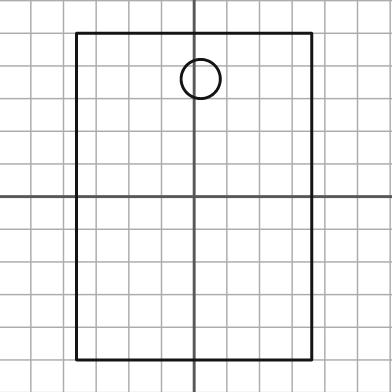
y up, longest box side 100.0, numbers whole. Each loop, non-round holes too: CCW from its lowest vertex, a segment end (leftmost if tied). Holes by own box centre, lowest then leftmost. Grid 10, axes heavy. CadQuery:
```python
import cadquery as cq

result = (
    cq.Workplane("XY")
    .moveTo(-36.0, -50.0)
    .lineTo(36.0, -50.0)
    .lineTo(36.0, 50.0)
    .lineTo(-36.0, 50.0)
    .close()
    .moveTo(2.0, 36.0)
    .circle(6.0)
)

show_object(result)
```